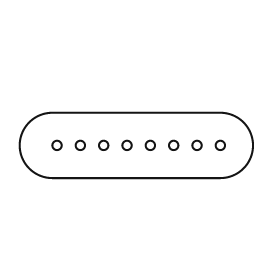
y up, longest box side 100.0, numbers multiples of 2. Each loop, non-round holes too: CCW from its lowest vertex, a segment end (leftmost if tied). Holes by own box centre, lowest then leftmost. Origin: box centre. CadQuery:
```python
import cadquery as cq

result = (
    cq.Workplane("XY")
    .moveTo(-36.0, -14.0)
    .lineTo(36.0, -14.0)
    .threePointArc((50.0, 0.0), (36.0, 14.0))
    .lineTo(-36.0, 14.0)
    .threePointArc((-50.0, 0.0), (-36.0, -14.0))
    .close()
    .moveTo(-34.0, 0.0)
    .circle(2.0)
    .moveTo(-24.0, 0.0)
    .circle(2.0)
    .moveTo(-14.0, 0.0)
    .circle(2.0)
    .moveTo(-4.0, 0.0)
    .circle(2.0)
    .moveTo(6.0, 0.0)
    .circle(2.0)
    .moveTo(16.0, 0.0)
    .circle(2.0)
    .moveTo(26.0, 0.0)
    .circle(2.0)
    .moveTo(36.0, 0.0)
    .circle(2.0)
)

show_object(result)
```